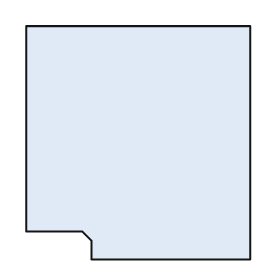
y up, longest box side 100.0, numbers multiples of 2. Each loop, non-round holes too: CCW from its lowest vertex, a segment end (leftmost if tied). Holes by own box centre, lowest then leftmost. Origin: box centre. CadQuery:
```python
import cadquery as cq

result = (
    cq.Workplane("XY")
    .moveTo(-20.0, -50.0)
    .lineTo(48.0, -50.0)
    .lineTo(48.0, 50.0)
    .lineTo(-48.0, 50.0)
    .lineTo(-48.0, -38.0)
    .lineTo(-24.0, -38.0)
    .lineTo(-20.0, -42.0)
    .close()
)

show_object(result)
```